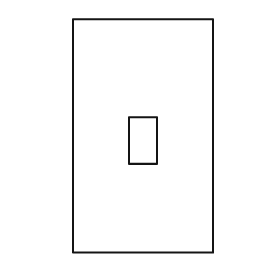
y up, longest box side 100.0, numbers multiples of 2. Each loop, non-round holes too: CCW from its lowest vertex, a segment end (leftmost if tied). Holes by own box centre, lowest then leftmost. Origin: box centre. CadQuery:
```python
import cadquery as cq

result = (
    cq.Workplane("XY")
    .moveTo(-30.0, -50.0)
    .lineTo(30.0, -50.0)
    .lineTo(30.0, 50.0)
    .lineTo(-30.0, 50.0)
    .close()
    .moveTo(-6.0, -12.0)
    .lineTo(6.0, -12.0)
    .lineTo(6.0, 8.0)
    .lineTo(-6.0, 8.0)
    .close()
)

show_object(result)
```